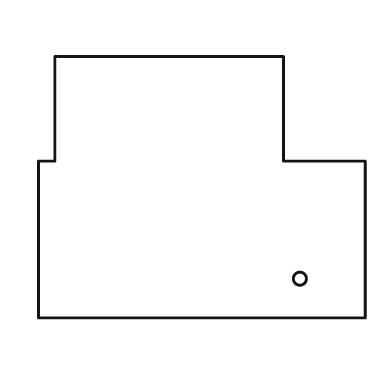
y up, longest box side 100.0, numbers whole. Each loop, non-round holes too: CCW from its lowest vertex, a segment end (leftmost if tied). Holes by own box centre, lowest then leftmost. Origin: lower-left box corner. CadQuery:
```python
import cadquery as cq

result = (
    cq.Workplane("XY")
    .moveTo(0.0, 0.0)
    .lineTo(100.0, 0.0)
    .lineTo(100.0, 48.0)
    .lineTo(75.0, 48.0)
    .lineTo(75.0, 80.0)
    .lineTo(5.0, 80.0)
    .lineTo(5.0, 48.0)
    .lineTo(0.0, 48.0)
    .close()
    .moveTo(80.0, 12.0)
    .circle(2.0)
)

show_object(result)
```